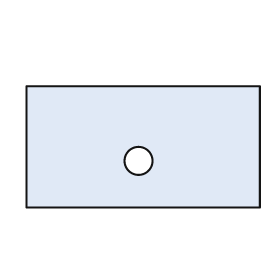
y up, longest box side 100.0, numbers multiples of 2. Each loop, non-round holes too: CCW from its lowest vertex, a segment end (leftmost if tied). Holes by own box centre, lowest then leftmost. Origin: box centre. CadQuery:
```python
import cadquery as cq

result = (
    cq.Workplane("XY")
    .moveTo(-50.0, -26.0)
    .lineTo(50.0, -26.0)
    .lineTo(50.0, 26.0)
    .lineTo(-50.0, 26.0)
    .close()
    .moveTo(-2.0, -6.0)
    .circle(6.0)
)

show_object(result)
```